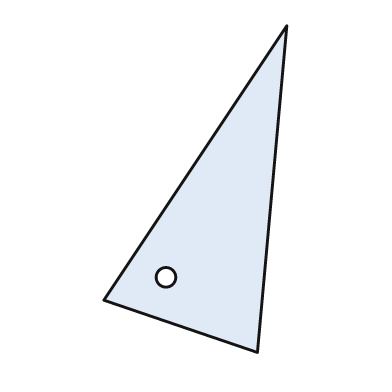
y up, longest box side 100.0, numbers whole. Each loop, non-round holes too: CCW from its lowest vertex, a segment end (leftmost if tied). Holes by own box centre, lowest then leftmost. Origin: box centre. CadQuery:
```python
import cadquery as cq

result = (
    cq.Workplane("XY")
    .moveTo(19.0, -50.0)
    .lineTo(28.0, 50.0)
    .lineTo(-28.0, -34.0)
    .close()
    .moveTo(-9.0, -27.0)
    .circle(3.0)
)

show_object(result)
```